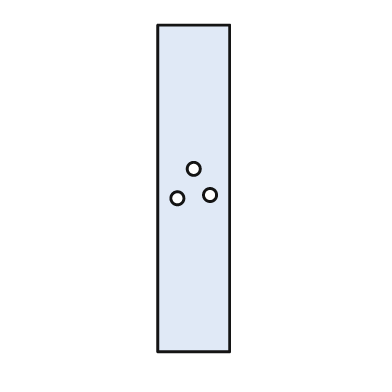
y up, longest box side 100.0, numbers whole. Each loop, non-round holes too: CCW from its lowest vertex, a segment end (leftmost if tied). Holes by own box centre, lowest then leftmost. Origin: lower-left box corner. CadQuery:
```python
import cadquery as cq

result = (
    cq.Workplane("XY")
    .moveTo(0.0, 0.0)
    .lineTo(22.0, 0.0)
    .lineTo(22.0, 100.0)
    .lineTo(0.0, 100.0)
    .close()
    .moveTo(6.0, 47.0)
    .circle(2.0)
    .moveTo(16.0, 48.0)
    .circle(2.0)
    .moveTo(11.0, 56.0)
    .circle(2.0)
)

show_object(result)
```